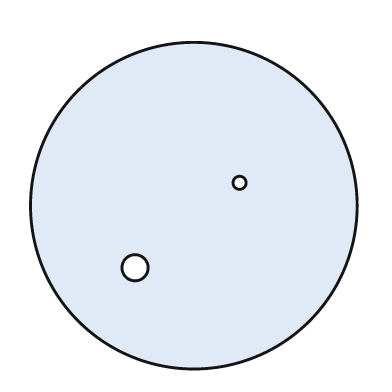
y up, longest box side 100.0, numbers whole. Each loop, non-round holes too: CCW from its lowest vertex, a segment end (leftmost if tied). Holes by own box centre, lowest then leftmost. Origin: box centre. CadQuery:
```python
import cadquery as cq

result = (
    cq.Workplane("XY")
    .moveTo(0.0, 0.0)
    .circle(50.0)
    .moveTo(-18.0, -19.0)
    .circle(4.0)
    .moveTo(14.0, 7.0)
    .circle(2.0)
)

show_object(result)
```